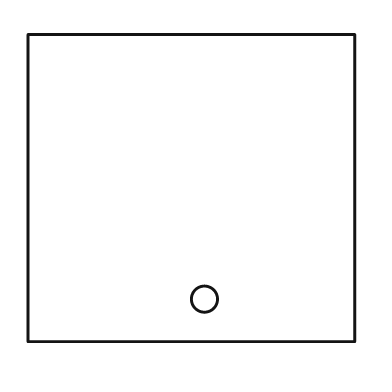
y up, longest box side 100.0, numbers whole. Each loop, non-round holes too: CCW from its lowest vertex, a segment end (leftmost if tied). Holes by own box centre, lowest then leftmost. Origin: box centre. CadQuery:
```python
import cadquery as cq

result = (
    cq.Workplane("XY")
    .moveTo(-50.0, -47.0)
    .lineTo(50.0, -47.0)
    .lineTo(50.0, 47.0)
    .lineTo(-50.0, 47.0)
    .close()
    .moveTo(4.0, -34.0)
    .circle(4.0)
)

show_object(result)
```